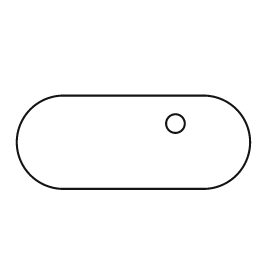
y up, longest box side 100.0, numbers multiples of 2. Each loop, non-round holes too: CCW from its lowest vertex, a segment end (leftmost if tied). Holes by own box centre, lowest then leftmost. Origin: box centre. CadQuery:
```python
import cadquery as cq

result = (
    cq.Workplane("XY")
    .moveTo(-30.0, -20.0)
    .lineTo(30.0, -20.0)
    .threePointArc((50.0, 0.0), (30.0, 20.0))
    .lineTo(-30.0, 20.0)
    .threePointArc((-50.0, 0.0), (-30.0, -20.0))
    .close()
    .moveTo(18.0, 8.0)
    .circle(4.0)
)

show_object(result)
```